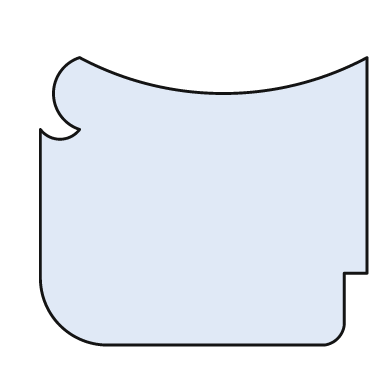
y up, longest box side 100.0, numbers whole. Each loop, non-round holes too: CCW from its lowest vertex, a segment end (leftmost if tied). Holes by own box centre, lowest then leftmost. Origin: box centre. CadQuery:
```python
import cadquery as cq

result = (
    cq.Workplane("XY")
    .moveTo(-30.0, -44.0)
    .lineTo(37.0, -44.0)
    .threePointArc((41.0, -42.0), (43.0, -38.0))
    .lineTo(43.0, -22.0)
    .lineTo(50.0, -22.0)
    .lineTo(50.0, 44.0)
    .threePointArc((6.0, 33.0), (-38.0, 44.0))
    .threePointArc((-46.0, 33.0), (-38.0, 22.0))
    .threePointArc((-44.0, 19.0), (-50.0, 22.0))
    .lineTo(-50.0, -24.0)
    .threePointArc((-44.0, -38.0), (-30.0, -44.0))
    .close()
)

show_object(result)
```